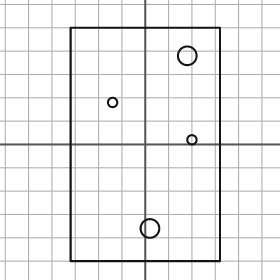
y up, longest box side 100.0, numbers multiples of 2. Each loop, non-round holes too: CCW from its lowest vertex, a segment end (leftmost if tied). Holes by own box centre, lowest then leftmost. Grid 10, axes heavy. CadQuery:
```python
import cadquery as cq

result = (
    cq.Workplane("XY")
    .moveTo(-32.0, -50.0)
    .lineTo(32.0, -50.0)
    .lineTo(32.0, 50.0)
    .lineTo(-32.0, 50.0)
    .close()
    .moveTo(2.0, -36.0)
    .circle(4.0)
    .moveTo(20.0, 2.0)
    .circle(2.0)
    .moveTo(-14.0, 18.0)
    .circle(2.0)
    .moveTo(18.0, 38.0)
    .circle(4.0)
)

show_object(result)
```